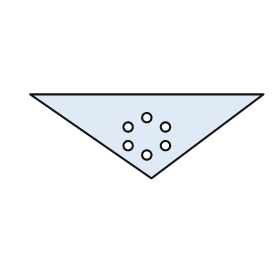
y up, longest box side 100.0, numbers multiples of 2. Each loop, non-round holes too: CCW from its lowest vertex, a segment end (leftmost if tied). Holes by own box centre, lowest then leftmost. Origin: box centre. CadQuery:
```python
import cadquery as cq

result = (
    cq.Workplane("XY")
    .moveTo(2.0, -18.0)
    .lineTo(50.0, 18.0)
    .lineTo(-50.0, 18.0)
    .close()
    .moveTo(0.0, -8.0)
    .circle(2.0)
    .moveTo(-8.0, -4.0)
    .circle(2.0)
    .moveTo(8.0, -4.0)
    .circle(2.0)
    .moveTo(-8.0, 4.0)
    .circle(2.0)
    .moveTo(8.0, 4.0)
    .circle(2.0)
    .moveTo(0.0, 8.0)
    .circle(2.0)
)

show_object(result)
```